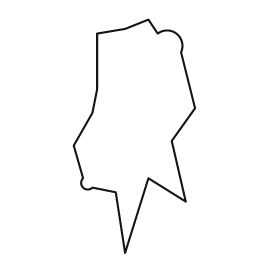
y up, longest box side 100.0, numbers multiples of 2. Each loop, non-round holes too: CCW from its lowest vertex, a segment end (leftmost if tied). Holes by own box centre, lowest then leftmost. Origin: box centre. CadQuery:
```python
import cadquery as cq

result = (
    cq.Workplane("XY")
    .moveTo(-4.0, -50.0)
    .lineTo(6.0, -18.0)
    .lineTo(22.0, -28.0)
    .lineTo(16.0, -2.0)
    .lineTo(26.0, 12.0)
    .lineTo(20.0, 36.0)
    .threePointArc((18.0, 44.0), (10.0, 44.0))
    .lineTo(6.0, 50.0)
    .lineTo(-4.0, 46.0)
    .lineTo(-16.0, 44.0)
    .lineTo(-16.0, 20.0)
    .lineTo(-18.0, 10.0)
    .lineTo(-26.0, -4.0)
    .lineTo(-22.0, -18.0)
    .threePointArc((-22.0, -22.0), (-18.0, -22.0))
    .lineTo(-8.0, -24.0)
    .close()
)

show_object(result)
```